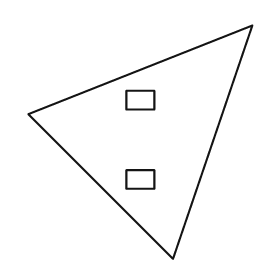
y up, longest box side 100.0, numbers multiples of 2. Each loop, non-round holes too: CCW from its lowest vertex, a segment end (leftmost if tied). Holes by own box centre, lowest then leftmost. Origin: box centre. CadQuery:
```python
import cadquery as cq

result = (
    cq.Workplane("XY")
    .moveTo(14.0, -50.0)
    .lineTo(48.0, 50.0)
    .lineTo(-48.0, 12.0)
    .close()
    .moveTo(-6.0, -20.0)
    .lineTo(6.0, -20.0)
    .lineTo(6.0, -12.0)
    .lineTo(-6.0, -12.0)
    .close()
    .moveTo(-6.0, 14.0)
    .lineTo(6.0, 14.0)
    .lineTo(6.0, 22.0)
    .lineTo(-6.0, 22.0)
    .close()
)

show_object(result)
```